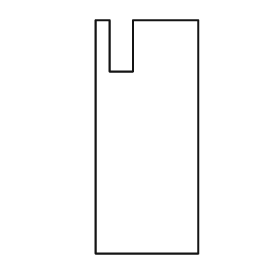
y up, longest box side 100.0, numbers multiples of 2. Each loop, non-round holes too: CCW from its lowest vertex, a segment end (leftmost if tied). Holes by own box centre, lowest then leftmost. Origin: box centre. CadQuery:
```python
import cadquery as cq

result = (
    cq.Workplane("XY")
    .moveTo(-22.0, -50.0)
    .lineTo(22.0, -50.0)
    .lineTo(22.0, 50.0)
    .lineTo(-6.0, 50.0)
    .lineTo(-6.0, 28.0)
    .lineTo(-16.0, 28.0)
    .lineTo(-16.0, 50.0)
    .lineTo(-22.0, 50.0)
    .close()
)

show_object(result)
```